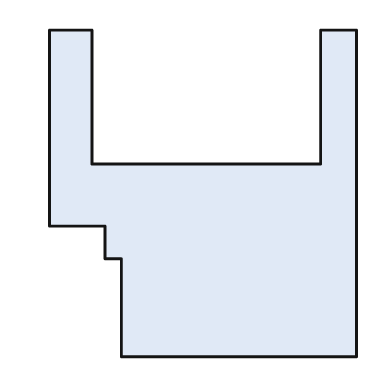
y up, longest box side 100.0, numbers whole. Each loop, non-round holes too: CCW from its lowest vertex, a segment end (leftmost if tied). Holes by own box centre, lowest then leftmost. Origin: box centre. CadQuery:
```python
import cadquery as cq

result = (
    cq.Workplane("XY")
    .moveTo(-25.0, -50.0)
    .lineTo(47.0, -50.0)
    .lineTo(47.0, 50.0)
    .lineTo(36.0, 50.0)
    .lineTo(36.0, 9.0)
    .lineTo(-34.0, 9.0)
    .lineTo(-34.0, 50.0)
    .lineTo(-47.0, 50.0)
    .lineTo(-47.0, -10.0)
    .lineTo(-30.0, -10.0)
    .lineTo(-30.0, -20.0)
    .lineTo(-25.0, -20.0)
    .close()
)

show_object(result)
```